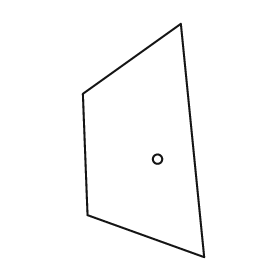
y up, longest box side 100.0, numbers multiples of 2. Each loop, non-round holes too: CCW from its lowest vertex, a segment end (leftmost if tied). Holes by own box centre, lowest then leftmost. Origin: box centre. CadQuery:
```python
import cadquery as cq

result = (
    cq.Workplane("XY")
    .moveTo(26.0, -50.0)
    .lineTo(16.0, 50.0)
    .lineTo(-26.0, 20.0)
    .lineTo(-24.0, -32.0)
    .close()
    .moveTo(6.0, -8.0)
    .circle(2.0)
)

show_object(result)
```